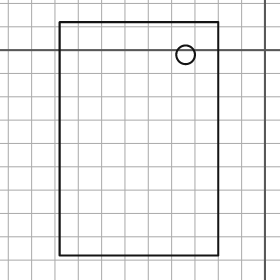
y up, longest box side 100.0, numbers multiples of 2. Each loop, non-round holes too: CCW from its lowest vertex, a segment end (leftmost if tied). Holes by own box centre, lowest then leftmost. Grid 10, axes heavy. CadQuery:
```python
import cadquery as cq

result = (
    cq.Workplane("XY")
    .moveTo(-88.0, -88.0)
    .lineTo(-20.0, -88.0)
    .lineTo(-20.0, 12.0)
    .lineTo(-88.0, 12.0)
    .close()
    .moveTo(-34.0, -2.0)
    .circle(4.0)
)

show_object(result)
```